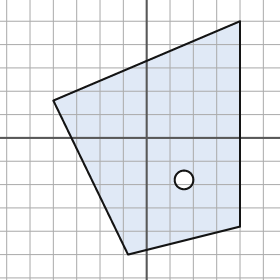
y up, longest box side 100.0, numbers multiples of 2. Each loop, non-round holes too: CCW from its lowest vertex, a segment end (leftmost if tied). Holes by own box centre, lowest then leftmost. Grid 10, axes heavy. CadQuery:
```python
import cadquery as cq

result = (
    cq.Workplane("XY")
    .moveTo(-8.0, -50.0)
    .lineTo(40.0, -38.0)
    .lineTo(40.0, 50.0)
    .lineTo(-40.0, 16.0)
    .close()
    .moveTo(16.0, -18.0)
    .circle(4.0)
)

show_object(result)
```